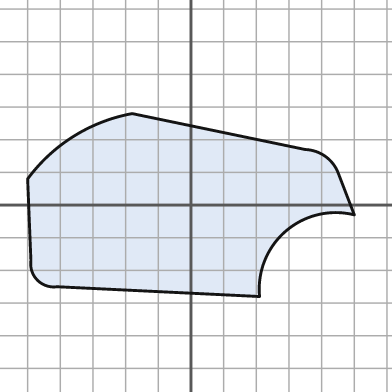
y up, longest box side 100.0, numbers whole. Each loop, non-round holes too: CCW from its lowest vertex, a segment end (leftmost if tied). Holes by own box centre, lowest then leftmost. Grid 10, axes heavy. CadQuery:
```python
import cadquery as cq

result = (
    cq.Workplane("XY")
    .moveTo(21.0, -28.0)
    .threePointArc((29.0, -8.0), (50.0, -3.0))
    .lineTo(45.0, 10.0)
    .threePointArc((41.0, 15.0), (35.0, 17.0))
    .lineTo(-18.0, 28.0)
    .threePointArc((-36.0, 21.0), (-50.0, 8.0))
    .lineTo(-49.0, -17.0)
    .threePointArc((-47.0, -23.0), (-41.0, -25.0))
    .close()
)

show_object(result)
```